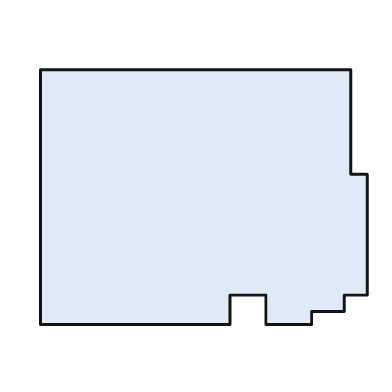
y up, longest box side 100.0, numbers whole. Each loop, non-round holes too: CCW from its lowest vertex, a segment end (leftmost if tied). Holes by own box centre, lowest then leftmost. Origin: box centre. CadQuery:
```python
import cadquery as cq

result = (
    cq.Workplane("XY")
    .moveTo(-50.0, -39.0)
    .lineTo(8.0, -39.0)
    .lineTo(8.0, -30.0)
    .lineTo(19.0, -30.0)
    .lineTo(19.0, -39.0)
    .lineTo(33.0, -39.0)
    .lineTo(33.0, -35.0)
    .lineTo(43.0, -35.0)
    .lineTo(43.0, -30.0)
    .lineTo(50.0, -30.0)
    .lineTo(50.0, 7.0)
    .lineTo(45.0, 7.0)
    .lineTo(45.0, 39.0)
    .lineTo(-50.0, 39.0)
    .close()
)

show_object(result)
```